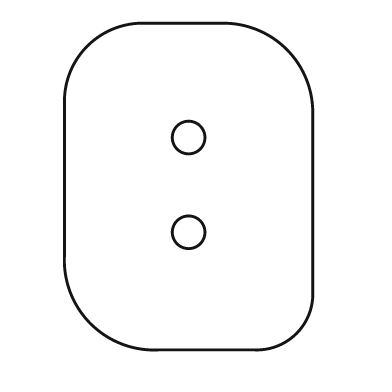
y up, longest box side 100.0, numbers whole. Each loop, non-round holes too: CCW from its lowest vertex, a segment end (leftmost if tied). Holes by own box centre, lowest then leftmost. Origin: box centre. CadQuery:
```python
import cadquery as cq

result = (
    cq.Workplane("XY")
    .moveTo(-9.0, -50.0)
    .lineTo(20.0, -50.0)
    .threePointArc((33.0, -45.0), (38.0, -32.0))
    .lineTo(38.0, 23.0)
    .threePointArc((30.0, 42.0), (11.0, 50.0))
    .lineTo(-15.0, 50.0)
    .threePointArc((-31.0, 43.0), (-38.0, 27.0))
    .lineTo(-38.0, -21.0)
    .threePointArc((-30.0, -42.0), (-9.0, -50.0))
    .close()
    .moveTo(0.0, -14.0)
    .circle(5.0)
    .moveTo(0.0, 15.0)
    .circle(5.0)
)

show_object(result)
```